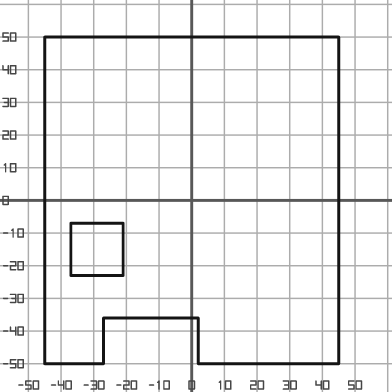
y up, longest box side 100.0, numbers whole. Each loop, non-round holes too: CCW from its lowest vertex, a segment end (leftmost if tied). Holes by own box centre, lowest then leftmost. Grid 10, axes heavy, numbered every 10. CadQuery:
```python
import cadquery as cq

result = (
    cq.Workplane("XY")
    .moveTo(-45.0, -50.0)
    .lineTo(-27.0, -50.0)
    .lineTo(-27.0, -36.0)
    .lineTo(2.0, -36.0)
    .lineTo(2.0, -50.0)
    .lineTo(45.0, -50.0)
    .lineTo(45.0, 50.0)
    .lineTo(-45.0, 50.0)
    .close()
    .moveTo(-37.0, -23.0)
    .lineTo(-21.0, -23.0)
    .lineTo(-21.0, -7.0)
    .lineTo(-37.0, -7.0)
    .close()
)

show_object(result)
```